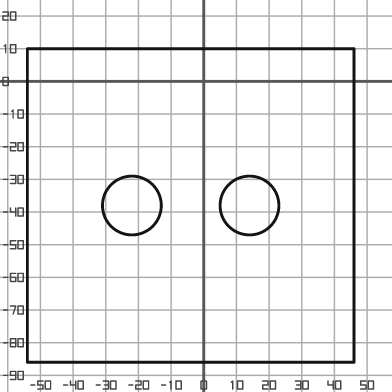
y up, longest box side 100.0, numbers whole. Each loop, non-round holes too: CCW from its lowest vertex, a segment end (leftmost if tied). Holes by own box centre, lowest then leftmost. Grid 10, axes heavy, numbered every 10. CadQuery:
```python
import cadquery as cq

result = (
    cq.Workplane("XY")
    .moveTo(-54.0, -86.0)
    .lineTo(46.0, -86.0)
    .lineTo(46.0, 10.0)
    .lineTo(-54.0, 10.0)
    .close()
    .moveTo(-22.0, -38.0)
    .circle(9.0)
    .moveTo(14.0, -38.0)
    .circle(9.0)
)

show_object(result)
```